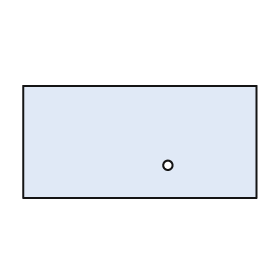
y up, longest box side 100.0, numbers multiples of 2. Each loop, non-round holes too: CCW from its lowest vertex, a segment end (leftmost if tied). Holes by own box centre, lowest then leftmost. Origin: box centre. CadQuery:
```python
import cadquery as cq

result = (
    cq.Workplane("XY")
    .moveTo(-50.0, -24.0)
    .lineTo(50.0, -24.0)
    .lineTo(50.0, 24.0)
    .lineTo(-50.0, 24.0)
    .close()
    .moveTo(12.0, -10.0)
    .circle(2.0)
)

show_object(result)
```